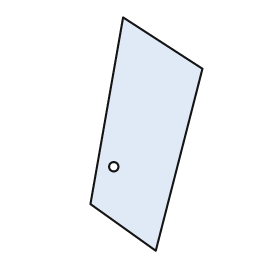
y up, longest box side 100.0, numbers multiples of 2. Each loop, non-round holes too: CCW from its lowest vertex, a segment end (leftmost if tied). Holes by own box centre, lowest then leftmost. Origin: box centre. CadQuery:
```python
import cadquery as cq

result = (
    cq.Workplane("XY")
    .moveTo(4.0, -50.0)
    .lineTo(24.0, 28.0)
    .lineTo(-10.0, 50.0)
    .lineTo(-24.0, -30.0)
    .close()
    .moveTo(-14.0, -14.0)
    .circle(2.0)
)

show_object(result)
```